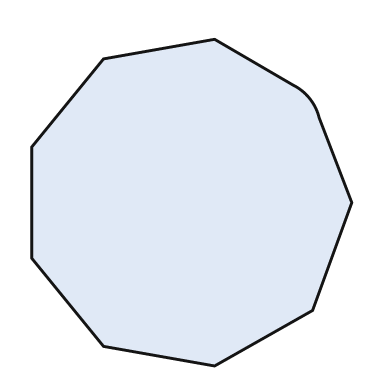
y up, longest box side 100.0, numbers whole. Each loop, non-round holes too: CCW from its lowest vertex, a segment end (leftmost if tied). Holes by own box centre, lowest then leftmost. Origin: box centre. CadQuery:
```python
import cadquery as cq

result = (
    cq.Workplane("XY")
    .moveTo(7.0, -50.0)
    .lineTo(37.0, -33.0)
    .lineTo(49.0, 0.0)
    .lineTo(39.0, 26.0)
    .threePointArc((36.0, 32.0), (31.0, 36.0))
    .lineTo(7.0, 50.0)
    .lineTo(-27.0, 44.0)
    .lineTo(-49.0, 17.0)
    .lineTo(-49.0, -17.0)
    .lineTo(-27.0, -44.0)
    .close()
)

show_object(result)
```